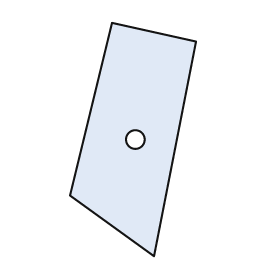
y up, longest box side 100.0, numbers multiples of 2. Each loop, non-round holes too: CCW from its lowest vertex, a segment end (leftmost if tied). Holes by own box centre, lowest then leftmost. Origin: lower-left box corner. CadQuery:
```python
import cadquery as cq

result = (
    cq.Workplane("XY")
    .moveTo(36.0, 0.0)
    .lineTo(54.0, 92.0)
    .lineTo(18.0, 100.0)
    .lineTo(0.0, 26.0)
    .close()
    .moveTo(28.0, 50.0)
    .circle(4.0)
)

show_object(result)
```